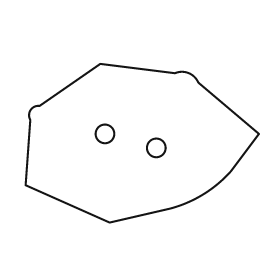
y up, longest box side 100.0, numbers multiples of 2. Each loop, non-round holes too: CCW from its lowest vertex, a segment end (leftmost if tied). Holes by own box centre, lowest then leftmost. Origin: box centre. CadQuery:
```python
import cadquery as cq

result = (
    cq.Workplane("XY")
    .moveTo(-14.0, -34.0)
    .lineTo(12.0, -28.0)
    .threePointArc((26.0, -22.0), (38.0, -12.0))
    .lineTo(50.0, 4.0)
    .lineTo(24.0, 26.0)
    .threePointArc((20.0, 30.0), (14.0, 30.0))
    .lineTo(-18.0, 34.0)
    .lineTo(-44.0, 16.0)
    .threePointArc((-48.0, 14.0), (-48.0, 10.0))
    .lineTo(-50.0, -18.0)
    .close()
    .moveTo(6.0, -2.0)
    .circle(4.0)
    .moveTo(-16.0, 4.0)
    .circle(4.0)
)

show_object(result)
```